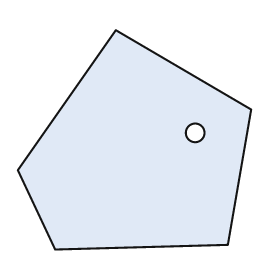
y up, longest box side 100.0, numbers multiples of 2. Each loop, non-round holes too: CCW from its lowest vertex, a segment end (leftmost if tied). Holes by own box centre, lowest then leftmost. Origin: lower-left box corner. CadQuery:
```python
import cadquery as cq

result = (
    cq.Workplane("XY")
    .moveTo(16.0, 0.0)
    .lineTo(90.0, 2.0)
    .lineTo(100.0, 60.0)
    .lineTo(42.0, 94.0)
    .lineTo(0.0, 34.0)
    .close()
    .moveTo(76.0, 50.0)
    .circle(4.0)
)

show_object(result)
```